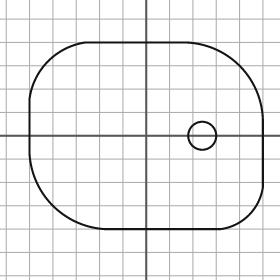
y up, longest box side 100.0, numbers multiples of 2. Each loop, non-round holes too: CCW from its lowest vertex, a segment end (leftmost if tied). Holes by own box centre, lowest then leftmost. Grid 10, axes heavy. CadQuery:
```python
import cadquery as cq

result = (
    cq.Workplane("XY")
    .moveTo(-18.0, -40.0)
    .lineTo(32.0, -40.0)
    .threePointArc((44.0, -34.0), (50.0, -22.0))
    .lineTo(50.0, 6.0)
    .threePointArc((40.0, 30.0), (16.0, 40.0))
    .lineTo(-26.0, 40.0)
    .threePointArc((-42.0, 32.0), (-50.0, 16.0))
    .lineTo(-50.0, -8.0)
    .threePointArc((-40.0, -30.0), (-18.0, -40.0))
    .close()
    .moveTo(24.0, 0.0)
    .circle(6.0)
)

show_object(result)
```